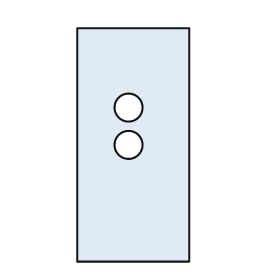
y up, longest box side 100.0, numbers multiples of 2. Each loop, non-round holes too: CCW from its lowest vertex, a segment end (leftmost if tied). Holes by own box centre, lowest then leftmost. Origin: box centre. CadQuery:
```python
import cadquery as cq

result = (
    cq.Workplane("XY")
    .moveTo(-24.0, -50.0)
    .lineTo(24.0, -50.0)
    .lineTo(24.0, 50.0)
    .lineTo(-24.0, 50.0)
    .close()
    .moveTo(-2.0, 0.0)
    .circle(6.0)
    .moveTo(-2.0, 16.0)
    .circle(6.0)
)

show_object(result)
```